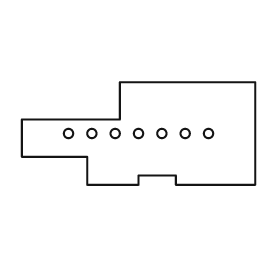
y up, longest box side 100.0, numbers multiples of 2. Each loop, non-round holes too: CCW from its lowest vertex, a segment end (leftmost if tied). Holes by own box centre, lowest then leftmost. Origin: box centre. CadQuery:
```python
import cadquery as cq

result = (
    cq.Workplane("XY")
    .moveTo(-22.0, -22.0)
    .lineTo(0.0, -22.0)
    .lineTo(0.0, -18.0)
    .lineTo(16.0, -18.0)
    .lineTo(16.0, -22.0)
    .lineTo(50.0, -22.0)
    .lineTo(50.0, 22.0)
    .lineTo(-8.0, 22.0)
    .lineTo(-8.0, 6.0)
    .lineTo(-50.0, 6.0)
    .lineTo(-50.0, -10.0)
    .lineTo(-22.0, -10.0)
    .close()
    .moveTo(-30.0, 0.0)
    .circle(2.0)
    .moveTo(-20.0, 0.0)
    .circle(2.0)
    .moveTo(-10.0, 0.0)
    .circle(2.0)
    .moveTo(0.0, 0.0)
    .circle(2.0)
    .moveTo(10.0, 0.0)
    .circle(2.0)
    .moveTo(20.0, 0.0)
    .circle(2.0)
    .moveTo(30.0, 0.0)
    .circle(2.0)
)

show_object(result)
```